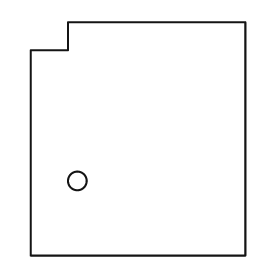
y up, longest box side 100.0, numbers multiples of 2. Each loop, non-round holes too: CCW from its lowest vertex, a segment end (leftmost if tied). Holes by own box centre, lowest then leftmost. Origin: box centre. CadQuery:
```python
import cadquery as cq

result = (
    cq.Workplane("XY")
    .moveTo(-46.0, -50.0)
    .lineTo(46.0, -50.0)
    .lineTo(46.0, 50.0)
    .lineTo(-30.0, 50.0)
    .lineTo(-30.0, 38.0)
    .lineTo(-46.0, 38.0)
    .close()
    .moveTo(-26.0, -18.0)
    .circle(4.0)
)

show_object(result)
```